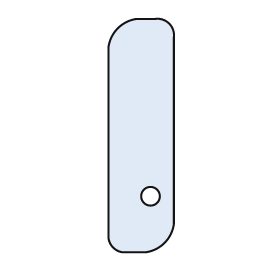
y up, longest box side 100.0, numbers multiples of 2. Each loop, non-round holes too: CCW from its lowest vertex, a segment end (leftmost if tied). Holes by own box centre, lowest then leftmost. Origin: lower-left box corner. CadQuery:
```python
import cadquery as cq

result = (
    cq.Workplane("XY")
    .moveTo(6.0, 0.0)
    .lineTo(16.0, 0.0)
    .threePointArc((24.0, 4.0), (28.0, 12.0))
    .lineTo(28.0, 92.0)
    .threePointArc((26.0, 98.0), (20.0, 100.0))
    .lineTo(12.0, 100.0)
    .threePointArc((4.0, 96.0), (0.0, 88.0))
    .lineTo(0.0, 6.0)
    .threePointArc((2.0, 2.0), (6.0, 0.0))
    .close()
    .moveTo(18.0, 24.0)
    .circle(4.0)
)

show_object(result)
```